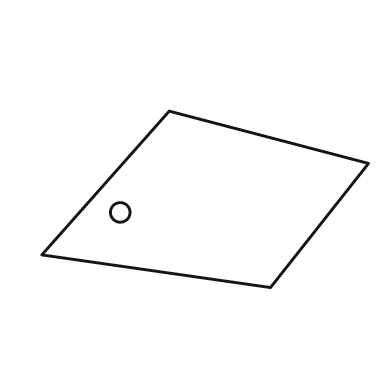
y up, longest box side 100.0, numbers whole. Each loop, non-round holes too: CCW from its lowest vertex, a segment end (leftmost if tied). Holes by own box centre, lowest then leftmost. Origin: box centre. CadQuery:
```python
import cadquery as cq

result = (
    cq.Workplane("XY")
    .moveTo(20.0, -27.0)
    .lineTo(50.0, 11.0)
    .lineTo(-11.0, 27.0)
    .lineTo(-50.0, -17.0)
    .close()
    .moveTo(-26.0, -4.0)
    .circle(3.0)
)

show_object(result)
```